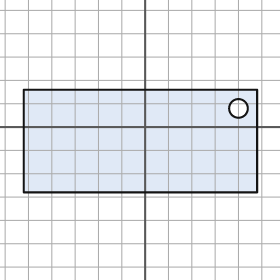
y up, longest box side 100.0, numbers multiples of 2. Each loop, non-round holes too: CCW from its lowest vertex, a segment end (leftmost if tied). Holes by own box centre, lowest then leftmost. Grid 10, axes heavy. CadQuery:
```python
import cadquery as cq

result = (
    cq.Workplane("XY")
    .moveTo(-52.0, -28.0)
    .lineTo(48.0, -28.0)
    .lineTo(48.0, 16.0)
    .lineTo(-52.0, 16.0)
    .close()
    .moveTo(40.0, 8.0)
    .circle(4.0)
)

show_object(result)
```